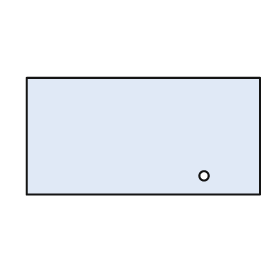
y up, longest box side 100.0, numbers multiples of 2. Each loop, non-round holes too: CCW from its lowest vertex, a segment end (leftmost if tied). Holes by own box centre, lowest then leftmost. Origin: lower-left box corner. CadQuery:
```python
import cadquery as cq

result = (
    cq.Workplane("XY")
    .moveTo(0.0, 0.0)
    .lineTo(100.0, 0.0)
    .lineTo(100.0, 50.0)
    .lineTo(0.0, 50.0)
    .close()
    .moveTo(76.0, 8.0)
    .circle(2.0)
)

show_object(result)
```